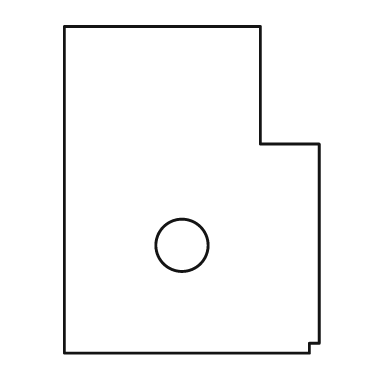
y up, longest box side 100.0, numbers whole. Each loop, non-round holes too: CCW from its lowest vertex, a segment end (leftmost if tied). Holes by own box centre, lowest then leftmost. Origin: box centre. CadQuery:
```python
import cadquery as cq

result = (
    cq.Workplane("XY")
    .moveTo(-39.0, -50.0)
    .lineTo(36.0, -50.0)
    .lineTo(36.0, -47.0)
    .lineTo(39.0, -47.0)
    .lineTo(39.0, 14.0)
    .lineTo(21.0, 14.0)
    .lineTo(21.0, 50.0)
    .lineTo(-39.0, 50.0)
    .close()
    .moveTo(-3.0, -17.0)
    .circle(8.0)
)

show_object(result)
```